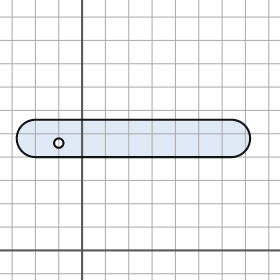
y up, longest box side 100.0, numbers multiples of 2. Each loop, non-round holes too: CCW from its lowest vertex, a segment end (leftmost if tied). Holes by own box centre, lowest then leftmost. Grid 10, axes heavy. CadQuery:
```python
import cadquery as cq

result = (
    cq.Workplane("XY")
    .moveTo(-20.0, 40.0)
    .lineTo(64.0, 40.0)
    .threePointArc((72.0, 48.0), (64.0, 56.0))
    .lineTo(-20.0, 56.0)
    .threePointArc((-28.0, 48.0), (-20.0, 40.0))
    .close()
    .moveTo(-10.0, 46.0)
    .circle(2.0)
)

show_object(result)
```